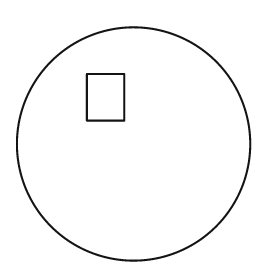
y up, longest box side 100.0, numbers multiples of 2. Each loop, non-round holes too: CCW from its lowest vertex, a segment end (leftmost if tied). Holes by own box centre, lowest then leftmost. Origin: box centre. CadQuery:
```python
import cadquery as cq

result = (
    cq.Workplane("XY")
    .moveTo(0.0, 0.0)
    .circle(50.0)
    .moveTo(-20.0, 10.0)
    .lineTo(-4.0, 10.0)
    .lineTo(-4.0, 30.0)
    .lineTo(-20.0, 30.0)
    .close()
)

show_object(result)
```